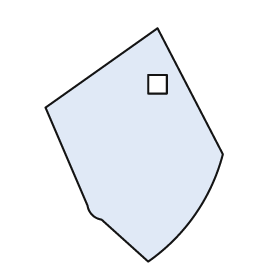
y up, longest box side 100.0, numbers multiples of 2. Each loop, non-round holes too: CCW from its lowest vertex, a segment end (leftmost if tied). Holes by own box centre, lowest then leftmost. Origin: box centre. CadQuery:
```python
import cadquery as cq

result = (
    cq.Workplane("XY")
    .moveTo(6.0, -50.0)
    .threePointArc((26.0, -30.0), (38.0, -4.0))
    .lineTo(10.0, 50.0)
    .lineTo(-38.0, 16.0)
    .lineTo(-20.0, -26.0)
    .threePointArc((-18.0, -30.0), (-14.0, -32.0))
    .close()
    .moveTo(6.0, 22.0)
    .lineTo(14.0, 22.0)
    .lineTo(14.0, 30.0)
    .lineTo(6.0, 30.0)
    .close()
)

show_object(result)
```